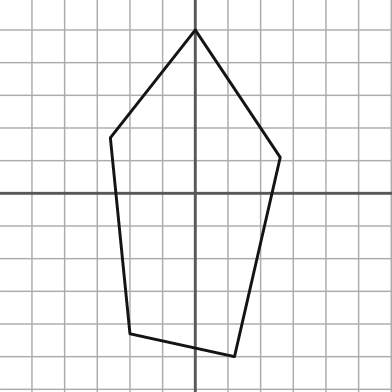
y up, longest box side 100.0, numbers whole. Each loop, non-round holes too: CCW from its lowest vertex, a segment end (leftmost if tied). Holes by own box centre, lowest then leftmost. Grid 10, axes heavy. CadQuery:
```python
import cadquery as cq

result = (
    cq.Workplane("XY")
    .moveTo(12.0, -50.0)
    .lineTo(26.0, 11.0)
    .lineTo(0.0, 50.0)
    .lineTo(-26.0, 17.0)
    .lineTo(-20.0, -43.0)
    .close()
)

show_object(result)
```